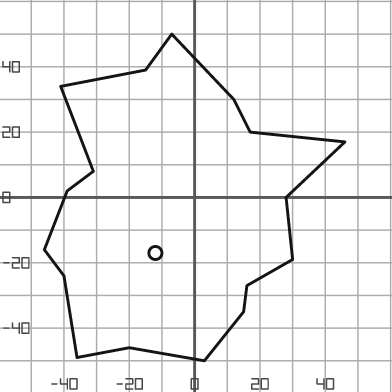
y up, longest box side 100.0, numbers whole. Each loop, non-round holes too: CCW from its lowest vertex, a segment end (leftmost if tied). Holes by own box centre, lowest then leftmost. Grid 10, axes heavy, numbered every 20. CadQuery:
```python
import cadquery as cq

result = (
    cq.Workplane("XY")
    .moveTo(3.0, -50.0)
    .lineTo(15.0, -35.0)
    .lineTo(16.0, -27.0)
    .lineTo(30.0, -19.0)
    .lineTo(28.0, 0.0)
    .lineTo(46.0, 17.0)
    .lineTo(17.0, 20.0)
    .lineTo(12.0, 30.0)
    .lineTo(-7.0, 50.0)
    .lineTo(-15.0, 39.0)
    .lineTo(-41.0, 34.0)
    .lineTo(-31.0, 8.0)
    .lineTo(-39.0, 2.0)
    .lineTo(-46.0, -16.0)
    .lineTo(-40.0, -24.0)
    .lineTo(-36.0, -49.0)
    .lineTo(-20.0, -46.0)
    .close()
    .moveTo(-12.0, -17.0)
    .circle(2.0)
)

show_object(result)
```